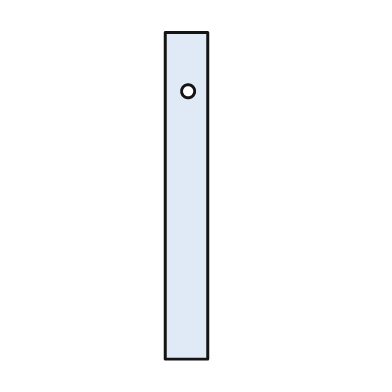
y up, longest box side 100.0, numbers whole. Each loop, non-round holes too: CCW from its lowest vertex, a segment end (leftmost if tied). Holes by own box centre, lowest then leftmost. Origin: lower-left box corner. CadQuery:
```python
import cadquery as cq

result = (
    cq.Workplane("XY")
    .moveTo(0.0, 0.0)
    .lineTo(13.0, 0.0)
    .lineTo(13.0, 100.0)
    .lineTo(0.0, 100.0)
    .close()
    .moveTo(7.0, 82.0)
    .circle(2.0)
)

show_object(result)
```